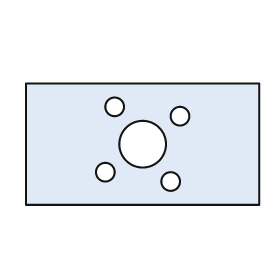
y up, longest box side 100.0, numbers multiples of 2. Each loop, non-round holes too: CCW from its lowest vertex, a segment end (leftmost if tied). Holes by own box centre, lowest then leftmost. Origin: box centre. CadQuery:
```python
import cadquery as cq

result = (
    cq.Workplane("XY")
    .moveTo(-50.0, -26.0)
    .lineTo(50.0, -26.0)
    .lineTo(50.0, 26.0)
    .lineTo(-50.0, 26.0)
    .close()
    .moveTo(12.0, -16.0)
    .circle(4.0)
    .moveTo(-16.0, -12.0)
    .circle(4.0)
    .moveTo(0.0, 0.0)
    .circle(10.0)
    .moveTo(16.0, 12.0)
    .circle(4.0)
    .moveTo(-12.0, 16.0)
    .circle(4.0)
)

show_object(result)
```